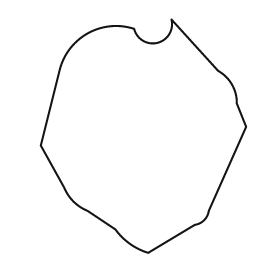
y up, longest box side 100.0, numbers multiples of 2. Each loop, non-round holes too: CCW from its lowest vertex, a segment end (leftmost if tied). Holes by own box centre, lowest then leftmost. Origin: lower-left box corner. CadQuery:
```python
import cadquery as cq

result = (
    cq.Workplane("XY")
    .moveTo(46.0, 0.0)
    .lineTo(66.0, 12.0)
    .threePointArc((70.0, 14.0), (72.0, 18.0))
    .lineTo(88.0, 54.0)
    .lineTo(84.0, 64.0)
    .threePointArc((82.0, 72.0), (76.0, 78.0))
    .lineTo(56.0, 100.0)
    .threePointArc((50.0, 90.0), (40.0, 96.0))
    .threePointArc((20.0, 94.0), (8.0, 78.0))
    .lineTo(0.0, 46.0)
    .lineTo(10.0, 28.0)
    .threePointArc((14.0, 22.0), (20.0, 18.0))
    .lineTo(32.0, 10.0)
    .threePointArc((38.0, 4.0), (46.0, 0.0))
    .close()
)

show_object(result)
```